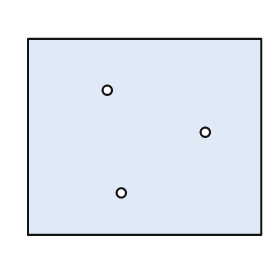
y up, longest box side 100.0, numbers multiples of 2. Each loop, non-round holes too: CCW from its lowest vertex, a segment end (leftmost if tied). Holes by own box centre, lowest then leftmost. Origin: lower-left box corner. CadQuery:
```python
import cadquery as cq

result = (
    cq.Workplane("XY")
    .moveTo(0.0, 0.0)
    .lineTo(100.0, 0.0)
    .lineTo(100.0, 84.0)
    .lineTo(0.0, 84.0)
    .close()
    .moveTo(40.0, 18.0)
    .circle(2.0)
    .moveTo(76.0, 44.0)
    .circle(2.0)
    .moveTo(34.0, 62.0)
    .circle(2.0)
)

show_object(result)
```